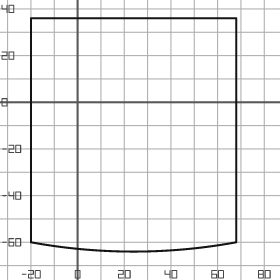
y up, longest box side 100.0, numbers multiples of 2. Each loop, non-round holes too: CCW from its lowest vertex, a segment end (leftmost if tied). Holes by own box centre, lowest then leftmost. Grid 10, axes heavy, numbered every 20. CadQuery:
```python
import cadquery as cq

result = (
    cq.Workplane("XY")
    .moveTo(-20.0, -60.0)
    .threePointArc((24.0, -64.0), (68.0, -60.0))
    .lineTo(68.0, 36.0)
    .lineTo(-20.0, 36.0)
    .close()
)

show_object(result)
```